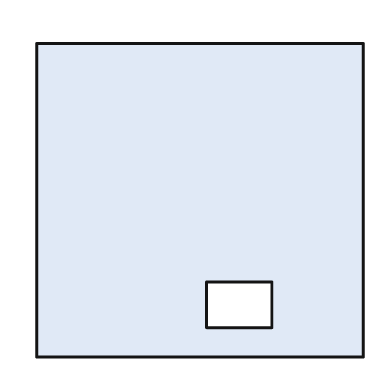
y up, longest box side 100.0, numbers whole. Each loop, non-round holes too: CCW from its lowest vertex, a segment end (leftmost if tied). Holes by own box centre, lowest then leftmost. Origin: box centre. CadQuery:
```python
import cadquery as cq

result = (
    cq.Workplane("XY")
    .moveTo(-50.0, -48.0)
    .lineTo(50.0, -48.0)
    .lineTo(50.0, 48.0)
    .lineTo(-50.0, 48.0)
    .close()
    .moveTo(2.0, -39.0)
    .lineTo(22.0, -39.0)
    .lineTo(22.0, -25.0)
    .lineTo(2.0, -25.0)
    .close()
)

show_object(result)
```